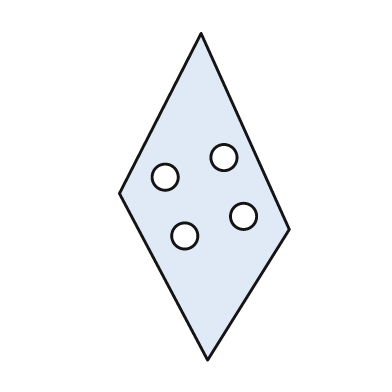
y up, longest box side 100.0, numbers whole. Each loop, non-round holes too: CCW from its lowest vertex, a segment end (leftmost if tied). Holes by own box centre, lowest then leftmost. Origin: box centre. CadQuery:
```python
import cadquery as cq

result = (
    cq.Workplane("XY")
    .moveTo(1.0, -50.0)
    .lineTo(26.0, -10.0)
    .lineTo(-1.0, 50.0)
    .lineTo(-26.0, 1.0)
    .close()
    .moveTo(-6.0, -12.0)
    .circle(4.0)
    .moveTo(12.0, -6.0)
    .circle(4.0)
    .moveTo(-12.0, 6.0)
    .circle(4.0)
    .moveTo(6.0, 12.0)
    .circle(4.0)
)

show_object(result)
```